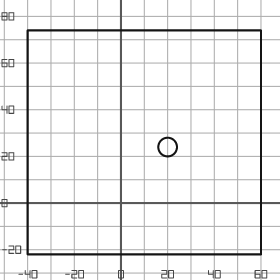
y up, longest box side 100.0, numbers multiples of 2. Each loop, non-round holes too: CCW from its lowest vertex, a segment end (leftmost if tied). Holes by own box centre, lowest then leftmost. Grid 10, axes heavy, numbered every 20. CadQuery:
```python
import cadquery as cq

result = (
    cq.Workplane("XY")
    .moveTo(-40.0, -22.0)
    .lineTo(60.0, -22.0)
    .lineTo(60.0, 74.0)
    .lineTo(-40.0, 74.0)
    .close()
    .moveTo(20.0, 24.0)
    .circle(4.0)
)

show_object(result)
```